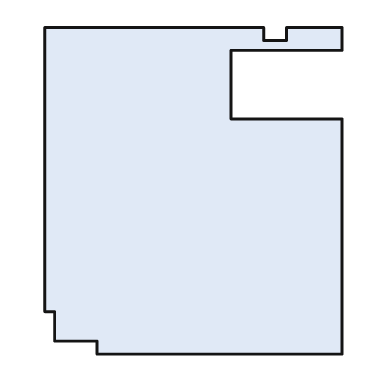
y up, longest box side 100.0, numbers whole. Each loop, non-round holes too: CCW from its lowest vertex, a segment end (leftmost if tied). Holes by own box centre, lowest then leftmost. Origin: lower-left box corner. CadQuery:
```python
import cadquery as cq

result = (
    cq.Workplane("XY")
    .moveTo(16.0, 0.0)
    .lineTo(91.0, 0.0)
    .lineTo(91.0, 72.0)
    .lineTo(57.0, 72.0)
    .lineTo(57.0, 93.0)
    .lineTo(91.0, 93.0)
    .lineTo(91.0, 100.0)
    .lineTo(74.0, 100.0)
    .lineTo(74.0, 96.0)
    .lineTo(67.0, 96.0)
    .lineTo(67.0, 100.0)
    .lineTo(0.0, 100.0)
    .lineTo(0.0, 13.0)
    .lineTo(3.0, 13.0)
    .lineTo(3.0, 4.0)
    .lineTo(16.0, 4.0)
    .close()
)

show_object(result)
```